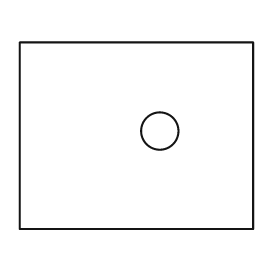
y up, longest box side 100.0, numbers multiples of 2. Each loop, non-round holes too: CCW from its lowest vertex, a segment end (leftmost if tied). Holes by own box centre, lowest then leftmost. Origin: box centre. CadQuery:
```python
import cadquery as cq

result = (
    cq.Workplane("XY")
    .moveTo(-50.0, -40.0)
    .lineTo(50.0, -40.0)
    .lineTo(50.0, 40.0)
    .lineTo(-50.0, 40.0)
    .close()
    .moveTo(10.0, 2.0)
    .circle(8.0)
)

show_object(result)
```